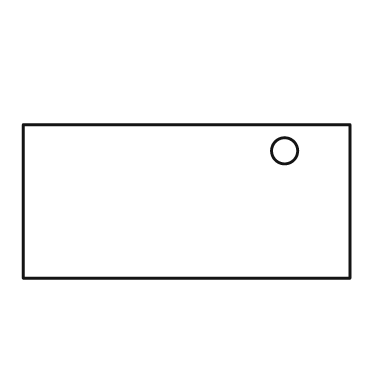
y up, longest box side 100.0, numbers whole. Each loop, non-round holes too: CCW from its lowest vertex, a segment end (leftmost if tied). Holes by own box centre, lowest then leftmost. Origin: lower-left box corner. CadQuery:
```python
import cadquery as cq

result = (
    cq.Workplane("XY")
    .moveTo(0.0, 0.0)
    .lineTo(100.0, 0.0)
    .lineTo(100.0, 47.0)
    .lineTo(0.0, 47.0)
    .close()
    .moveTo(80.0, 39.0)
    .circle(4.0)
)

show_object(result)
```